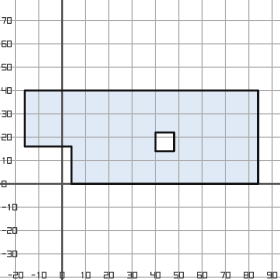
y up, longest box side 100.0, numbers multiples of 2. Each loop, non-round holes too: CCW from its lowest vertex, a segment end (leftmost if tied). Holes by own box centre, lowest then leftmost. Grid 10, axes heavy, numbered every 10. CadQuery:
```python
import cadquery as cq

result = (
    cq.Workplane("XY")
    .moveTo(4.0, 0.0)
    .lineTo(84.0, 0.0)
    .lineTo(84.0, 40.0)
    .lineTo(-16.0, 40.0)
    .lineTo(-16.0, 16.0)
    .lineTo(4.0, 16.0)
    .close()
    .moveTo(40.0, 14.0)
    .lineTo(48.0, 14.0)
    .lineTo(48.0, 22.0)
    .lineTo(40.0, 22.0)
    .close()
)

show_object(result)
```